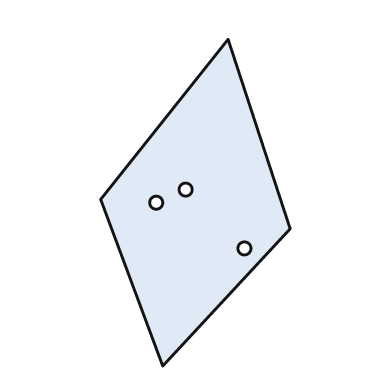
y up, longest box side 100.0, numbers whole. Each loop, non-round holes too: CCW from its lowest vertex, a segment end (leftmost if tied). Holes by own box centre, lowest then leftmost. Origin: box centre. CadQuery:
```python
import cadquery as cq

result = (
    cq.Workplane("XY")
    .moveTo(-10.0, -50.0)
    .lineTo(29.0, -8.0)
    .lineTo(10.0, 50.0)
    .lineTo(-29.0, 1.0)
    .close()
    .moveTo(15.0, -14.0)
    .circle(2.0)
    .moveTo(-12.0, 0.0)
    .circle(2.0)
    .moveTo(-3.0, 4.0)
    .circle(2.0)
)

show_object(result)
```